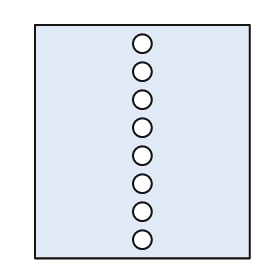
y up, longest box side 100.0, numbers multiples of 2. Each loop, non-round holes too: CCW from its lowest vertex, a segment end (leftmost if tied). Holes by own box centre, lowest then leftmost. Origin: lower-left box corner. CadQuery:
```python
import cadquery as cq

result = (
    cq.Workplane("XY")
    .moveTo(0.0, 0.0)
    .lineTo(92.0, 0.0)
    .lineTo(92.0, 100.0)
    .lineTo(0.0, 100.0)
    .close()
    .moveTo(46.0, 8.0)
    .circle(4.0)
    .moveTo(46.0, 20.0)
    .circle(4.0)
    .moveTo(46.0, 32.0)
    .circle(4.0)
    .moveTo(46.0, 44.0)
    .circle(4.0)
    .moveTo(46.0, 56.0)
    .circle(4.0)
    .moveTo(46.0, 68.0)
    .circle(4.0)
    .moveTo(46.0, 80.0)
    .circle(4.0)
    .moveTo(46.0, 92.0)
    .circle(4.0)
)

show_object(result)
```